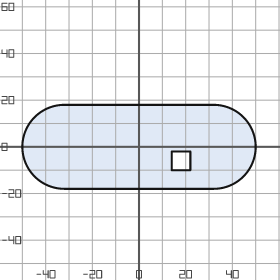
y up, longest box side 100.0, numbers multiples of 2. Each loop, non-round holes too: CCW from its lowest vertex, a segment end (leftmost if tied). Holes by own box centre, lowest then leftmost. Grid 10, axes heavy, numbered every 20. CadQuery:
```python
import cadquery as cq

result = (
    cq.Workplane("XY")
    .moveTo(-32.0, -18.0)
    .lineTo(32.0, -18.0)
    .threePointArc((50.0, 0.0), (32.0, 18.0))
    .lineTo(-32.0, 18.0)
    .threePointArc((-50.0, 0.0), (-32.0, -18.0))
    .close()
    .moveTo(14.0, -10.0)
    .lineTo(22.0, -10.0)
    .lineTo(22.0, -2.0)
    .lineTo(14.0, -2.0)
    .close()
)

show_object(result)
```